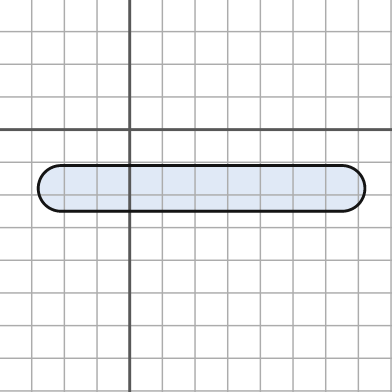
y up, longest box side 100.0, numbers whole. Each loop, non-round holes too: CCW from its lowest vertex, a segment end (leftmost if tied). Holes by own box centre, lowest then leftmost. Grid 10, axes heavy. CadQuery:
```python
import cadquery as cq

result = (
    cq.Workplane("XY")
    .moveTo(-21.0, -25.0)
    .lineTo(65.0, -25.0)
    .threePointArc((72.0, -18.0), (65.0, -11.0))
    .lineTo(-21.0, -11.0)
    .threePointArc((-28.0, -18.0), (-21.0, -25.0))
    .close()
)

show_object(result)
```